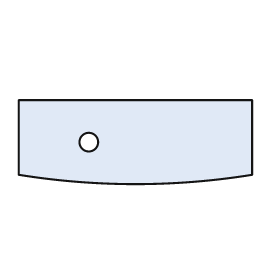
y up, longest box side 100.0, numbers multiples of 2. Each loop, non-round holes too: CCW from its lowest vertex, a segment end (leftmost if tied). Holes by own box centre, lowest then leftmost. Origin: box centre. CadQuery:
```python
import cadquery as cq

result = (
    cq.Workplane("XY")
    .moveTo(-50.0, -14.0)
    .threePointArc((0.0, -18.0), (50.0, -14.0))
    .lineTo(50.0, 18.0)
    .lineTo(-50.0, 18.0)
    .close()
    .moveTo(-20.0, 0.0)
    .circle(4.0)
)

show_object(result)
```